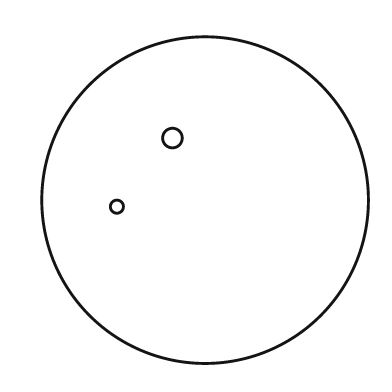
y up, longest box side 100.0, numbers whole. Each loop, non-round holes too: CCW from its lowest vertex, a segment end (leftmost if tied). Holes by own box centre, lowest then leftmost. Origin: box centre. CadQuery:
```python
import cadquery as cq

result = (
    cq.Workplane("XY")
    .moveTo(0.0, 0.0)
    .circle(50.0)
    .moveTo(-27.0, -2.0)
    .circle(2.0)
    .moveTo(-10.0, 19.0)
    .circle(3.0)
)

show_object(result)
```